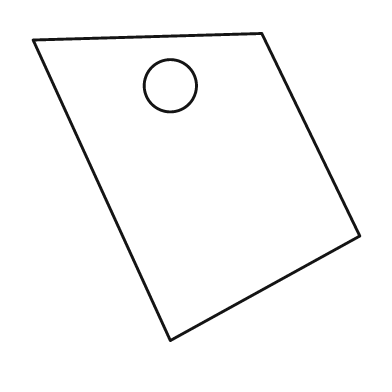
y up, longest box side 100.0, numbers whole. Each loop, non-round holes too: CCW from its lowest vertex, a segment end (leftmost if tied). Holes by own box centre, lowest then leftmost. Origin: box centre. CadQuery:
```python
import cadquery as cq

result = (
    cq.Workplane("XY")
    .moveTo(-8.0, -47.0)
    .lineTo(50.0, -15.0)
    .lineTo(20.0, 47.0)
    .lineTo(-50.0, 45.0)
    .close()
    .moveTo(-8.0, 31.0)
    .circle(8.0)
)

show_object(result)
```